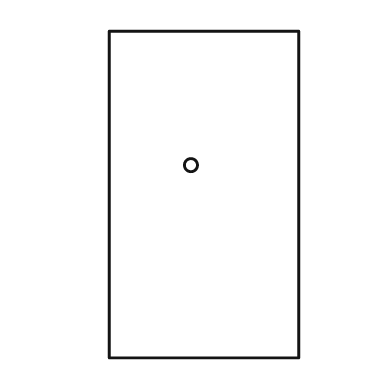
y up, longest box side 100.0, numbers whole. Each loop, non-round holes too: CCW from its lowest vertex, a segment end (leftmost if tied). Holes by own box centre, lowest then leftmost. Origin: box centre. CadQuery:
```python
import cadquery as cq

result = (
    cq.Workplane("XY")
    .moveTo(-29.0, -50.0)
    .lineTo(29.0, -50.0)
    .lineTo(29.0, 50.0)
    .lineTo(-29.0, 50.0)
    .close()
    .moveTo(-4.0, 9.0)
    .circle(2.0)
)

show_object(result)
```